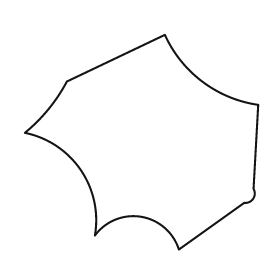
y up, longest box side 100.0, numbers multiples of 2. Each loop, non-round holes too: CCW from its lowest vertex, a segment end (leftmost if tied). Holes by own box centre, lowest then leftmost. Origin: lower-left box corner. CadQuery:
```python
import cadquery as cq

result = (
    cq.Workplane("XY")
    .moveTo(66.0, 0.0)
    .lineTo(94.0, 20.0)
    .threePointArc((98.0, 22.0), (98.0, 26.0))
    .lineTo(100.0, 62.0)
    .threePointArc((76.0, 72.0), (60.0, 92.0))
    .lineTo(18.0, 72.0)
    .threePointArc((10.0, 60.0), (0.0, 50.0))
    .threePointArc((24.0, 34.0), (30.0, 6.0))
    .threePointArc((50.0, 14.0), (66.0, 0.0))
    .close()
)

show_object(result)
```